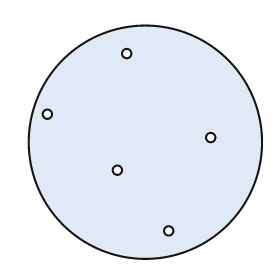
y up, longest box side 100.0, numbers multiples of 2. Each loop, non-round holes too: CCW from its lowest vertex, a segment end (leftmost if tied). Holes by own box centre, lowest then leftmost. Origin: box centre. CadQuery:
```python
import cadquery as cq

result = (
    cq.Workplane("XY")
    .moveTo(0.0, 0.0)
    .circle(50.0)
    .moveTo(10.0, -38.0)
    .circle(2.0)
    .moveTo(-12.0, -12.0)
    .circle(2.0)
    .moveTo(28.0, 2.0)
    .circle(2.0)
    .moveTo(-42.0, 12.0)
    .circle(2.0)
    .moveTo(-8.0, 38.0)
    .circle(2.0)
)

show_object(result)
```